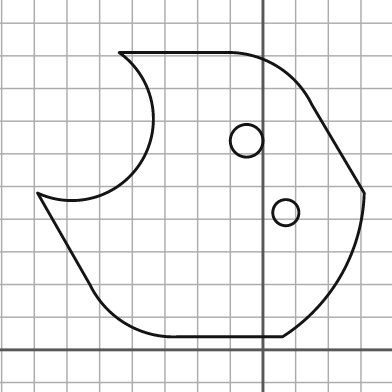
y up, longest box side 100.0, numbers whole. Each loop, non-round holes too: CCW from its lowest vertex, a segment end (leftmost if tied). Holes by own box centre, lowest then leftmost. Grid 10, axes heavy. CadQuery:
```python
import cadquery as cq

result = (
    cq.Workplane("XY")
    .moveTo(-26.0, 4.0)
    .lineTo(6.0, 4.0)
    .threePointArc((24.0, 23.0), (31.0, 48.0))
    .lineTo(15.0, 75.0)
    .threePointArc((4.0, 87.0), (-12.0, 91.0))
    .lineTo(-44.0, 91.0)
    .threePointArc((-37.0, 58.0), (-69.0, 48.0))
    .lineTo(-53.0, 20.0)
    .threePointArc((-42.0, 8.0), (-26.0, 4.0))
    .close()
    .moveTo(7.0, 42.0)
    .circle(4.0)
    .moveTo(-5.0, 64.0)
    .circle(5.0)
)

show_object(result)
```